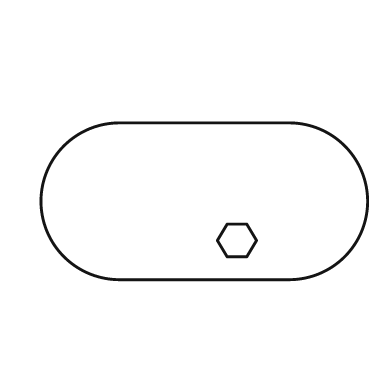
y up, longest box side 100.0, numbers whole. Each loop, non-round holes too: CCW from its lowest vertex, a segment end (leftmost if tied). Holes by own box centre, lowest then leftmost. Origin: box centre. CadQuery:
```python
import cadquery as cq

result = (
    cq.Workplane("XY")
    .moveTo(-26.0, -24.0)
    .lineTo(26.0, -24.0)
    .threePointArc((50.0, 0.0), (26.0, 24.0))
    .lineTo(-26.0, 24.0)
    .threePointArc((-50.0, 0.0), (-26.0, -24.0))
    .close()
    .moveTo(7.0, -17.0)
    .lineTo(13.0, -17.0)
    .lineTo(16.0, -12.0)
    .lineTo(13.0, -7.0)
    .lineTo(7.0, -7.0)
    .lineTo(4.0, -12.0)
    .close()
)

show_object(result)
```